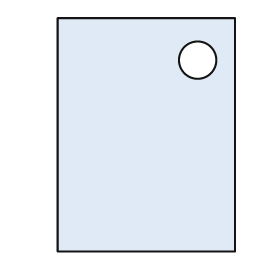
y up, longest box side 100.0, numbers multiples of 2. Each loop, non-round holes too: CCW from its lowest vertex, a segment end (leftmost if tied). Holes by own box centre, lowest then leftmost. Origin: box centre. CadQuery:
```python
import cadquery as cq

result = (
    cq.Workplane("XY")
    .moveTo(-38.0, -50.0)
    .lineTo(38.0, -50.0)
    .lineTo(38.0, 50.0)
    .lineTo(-38.0, 50.0)
    .close()
    .moveTo(22.0, 32.0)
    .circle(8.0)
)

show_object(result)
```